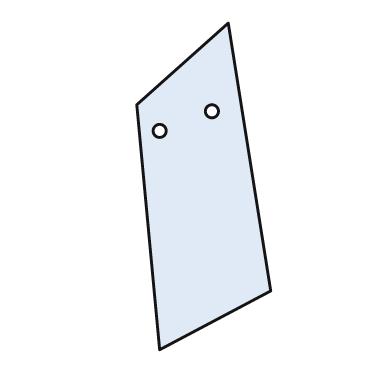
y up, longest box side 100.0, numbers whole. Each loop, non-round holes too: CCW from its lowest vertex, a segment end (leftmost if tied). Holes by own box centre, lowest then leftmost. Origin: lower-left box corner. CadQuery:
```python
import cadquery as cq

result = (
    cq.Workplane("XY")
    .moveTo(7.0, 0.0)
    .lineTo(41.0, 18.0)
    .lineTo(28.0, 100.0)
    .lineTo(0.0, 75.0)
    .close()
    .moveTo(7.0, 67.0)
    .circle(2.0)
    .moveTo(23.0, 73.0)
    .circle(2.0)
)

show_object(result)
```